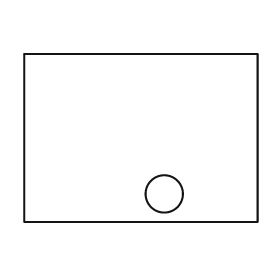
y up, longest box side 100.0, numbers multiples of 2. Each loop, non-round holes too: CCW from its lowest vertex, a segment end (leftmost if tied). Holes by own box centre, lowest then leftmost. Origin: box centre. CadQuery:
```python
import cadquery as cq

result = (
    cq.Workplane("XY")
    .moveTo(-50.0, -36.0)
    .lineTo(50.0, -36.0)
    .lineTo(50.0, 36.0)
    .lineTo(-50.0, 36.0)
    .close()
    .moveTo(10.0, -24.0)
    .circle(8.0)
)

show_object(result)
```